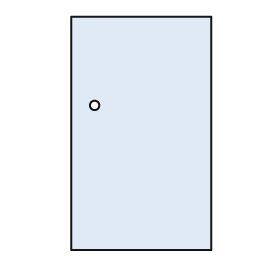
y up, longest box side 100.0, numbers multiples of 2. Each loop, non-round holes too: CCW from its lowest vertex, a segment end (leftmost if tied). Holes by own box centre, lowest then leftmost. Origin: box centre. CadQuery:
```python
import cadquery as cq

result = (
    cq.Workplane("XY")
    .moveTo(-30.0, -50.0)
    .lineTo(30.0, -50.0)
    .lineTo(30.0, 50.0)
    .lineTo(-30.0, 50.0)
    .close()
    .moveTo(-20.0, 12.0)
    .circle(2.0)
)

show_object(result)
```